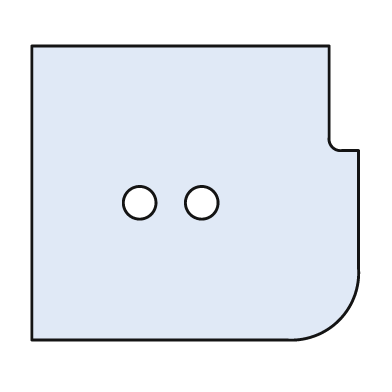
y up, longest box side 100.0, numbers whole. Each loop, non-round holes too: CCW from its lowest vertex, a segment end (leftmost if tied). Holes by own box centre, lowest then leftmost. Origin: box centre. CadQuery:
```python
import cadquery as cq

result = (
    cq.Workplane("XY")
    .moveTo(-50.0, -45.0)
    .lineTo(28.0, -45.0)
    .threePointArc((44.0, -39.0), (50.0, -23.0))
    .lineTo(50.0, 13.0)
    .lineTo(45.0, 13.0)
    .threePointArc((42.0, 14.0), (41.0, 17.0))
    .lineTo(41.0, 45.0)
    .lineTo(-50.0, 45.0)
    .close()
    .moveTo(-17.0, -3.0)
    .circle(5.0)
    .moveTo(2.0, -3.0)
    .circle(5.0)
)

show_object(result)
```